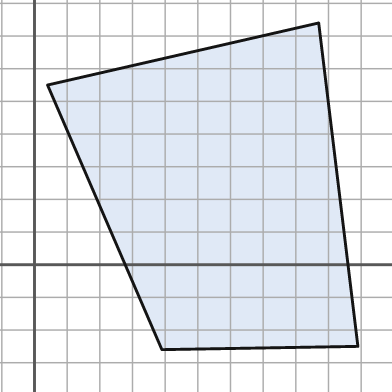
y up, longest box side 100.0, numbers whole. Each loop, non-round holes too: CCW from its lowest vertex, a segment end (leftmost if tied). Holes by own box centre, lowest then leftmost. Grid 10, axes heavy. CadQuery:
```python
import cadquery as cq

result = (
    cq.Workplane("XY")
    .moveTo(39.0, -26.0)
    .lineTo(99.0, -25.0)
    .lineTo(87.0, 74.0)
    .lineTo(4.0, 55.0)
    .close()
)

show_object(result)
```